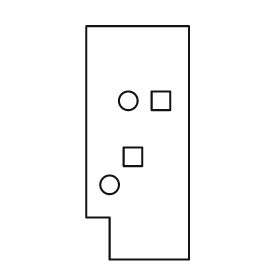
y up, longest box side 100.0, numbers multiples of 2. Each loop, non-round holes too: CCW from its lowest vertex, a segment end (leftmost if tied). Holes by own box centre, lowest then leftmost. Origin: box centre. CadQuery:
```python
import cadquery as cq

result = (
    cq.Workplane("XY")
    .moveTo(-12.0, -50.0)
    .lineTo(22.0, -50.0)
    .lineTo(22.0, 50.0)
    .lineTo(-22.0, 50.0)
    .lineTo(-22.0, -32.0)
    .lineTo(-12.0, -32.0)
    .close()
    .moveTo(-12.0, -18.0)
    .circle(4.0)
    .moveTo(-6.0, -10.0)
    .lineTo(2.0, -10.0)
    .lineTo(2.0, -2.0)
    .lineTo(-6.0, -2.0)
    .close()
    .moveTo(-4.0, 18.0)
    .circle(4.0)
    .moveTo(6.0, 14.0)
    .lineTo(14.0, 14.0)
    .lineTo(14.0, 22.0)
    .lineTo(6.0, 22.0)
    .close()
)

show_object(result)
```